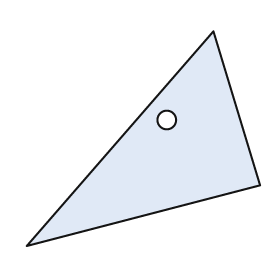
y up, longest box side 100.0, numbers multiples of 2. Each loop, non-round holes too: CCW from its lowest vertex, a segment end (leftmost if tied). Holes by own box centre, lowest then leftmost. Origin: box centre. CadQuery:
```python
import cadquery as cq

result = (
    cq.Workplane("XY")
    .moveTo(-50.0, -46.0)
    .lineTo(50.0, -20.0)
    .lineTo(30.0, 46.0)
    .close()
    .moveTo(10.0, 8.0)
    .circle(4.0)
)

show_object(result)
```